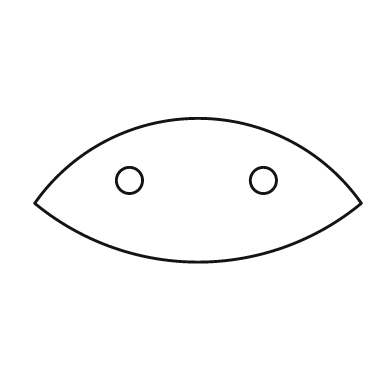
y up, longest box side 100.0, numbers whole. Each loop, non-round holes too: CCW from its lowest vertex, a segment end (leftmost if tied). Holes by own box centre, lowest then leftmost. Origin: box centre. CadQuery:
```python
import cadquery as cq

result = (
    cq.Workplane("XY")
    .moveTo(-50.0, -4.0)
    .threePointArc((0.0, -22.0), (50.0, -4.0))
    .threePointArc((0.0, 22.0), (-50.0, -4.0))
    .close()
    .moveTo(-21.0, 3.0)
    .circle(4.0)
    .moveTo(20.0, 3.0)
    .circle(4.0)
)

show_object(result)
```